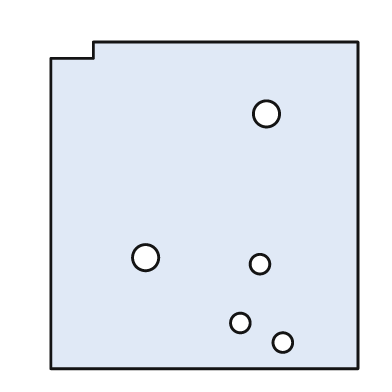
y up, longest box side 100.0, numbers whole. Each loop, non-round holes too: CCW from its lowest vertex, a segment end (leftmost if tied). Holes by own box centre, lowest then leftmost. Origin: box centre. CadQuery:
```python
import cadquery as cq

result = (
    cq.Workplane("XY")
    .moveTo(-47.0, -50.0)
    .lineTo(47.0, -50.0)
    .lineTo(47.0, 50.0)
    .lineTo(-34.0, 50.0)
    .lineTo(-34.0, 45.0)
    .lineTo(-47.0, 45.0)
    .close()
    .moveTo(24.0, -42.0)
    .circle(3.0)
    .moveTo(11.0, -36.0)
    .circle(3.0)
    .moveTo(17.0, -18.0)
    .circle(3.0)
    .moveTo(-18.0, -16.0)
    .circle(4.0)
    .moveTo(19.0, 28.0)
    .circle(4.0)
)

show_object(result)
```